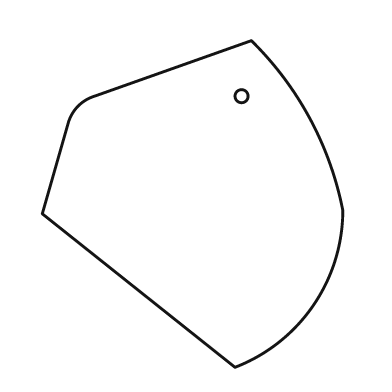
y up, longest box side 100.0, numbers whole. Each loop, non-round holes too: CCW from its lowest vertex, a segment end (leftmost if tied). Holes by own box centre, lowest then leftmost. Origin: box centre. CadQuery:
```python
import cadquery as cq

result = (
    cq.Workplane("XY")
    .moveTo(13.0, -50.0)
    .threePointArc((37.0, -31.0), (46.0, -2.0))
    .threePointArc((36.0, 26.0), (18.0, 50.0))
    .lineTo(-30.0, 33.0)
    .threePointArc((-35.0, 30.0), (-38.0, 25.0))
    .lineTo(-46.0, -3.0)
    .close()
    .moveTo(15.0, 33.0)
    .circle(2.0)
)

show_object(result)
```